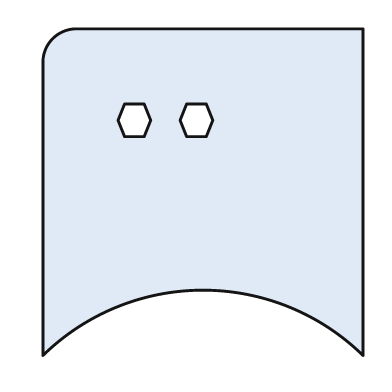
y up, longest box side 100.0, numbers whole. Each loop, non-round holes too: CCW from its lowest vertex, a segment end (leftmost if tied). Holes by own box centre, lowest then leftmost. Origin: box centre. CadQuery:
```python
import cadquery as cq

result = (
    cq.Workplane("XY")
    .moveTo(-49.0, -50.0)
    .threePointArc((0.0, -30.0), (49.0, -50.0))
    .lineTo(49.0, 50.0)
    .lineTo(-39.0, 50.0)
    .threePointArc((-46.0, 47.0), (-49.0, 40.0))
    .close()
    .moveTo(-24.0, 17.0)
    .lineTo(-18.0, 17.0)
    .lineTo(-16.0, 22.0)
    .lineTo(-18.0, 27.0)
    .lineTo(-24.0, 27.0)
    .lineTo(-26.0, 22.0)
    .close()
    .moveTo(-5.0, 17.0)
    .lineTo(1.0, 17.0)
    .lineTo(3.0, 22.0)
    .lineTo(1.0, 27.0)
    .lineTo(-5.0, 27.0)
    .lineTo(-7.0, 22.0)
    .close()
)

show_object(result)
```